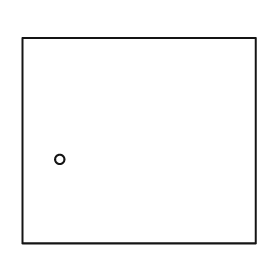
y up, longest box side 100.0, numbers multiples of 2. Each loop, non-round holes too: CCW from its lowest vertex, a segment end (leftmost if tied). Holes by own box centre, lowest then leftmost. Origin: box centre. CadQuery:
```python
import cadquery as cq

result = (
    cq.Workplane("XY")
    .moveTo(-50.0, -44.0)
    .lineTo(50.0, -44.0)
    .lineTo(50.0, 44.0)
    .lineTo(-50.0, 44.0)
    .close()
    .moveTo(-34.0, -8.0)
    .circle(2.0)
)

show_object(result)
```